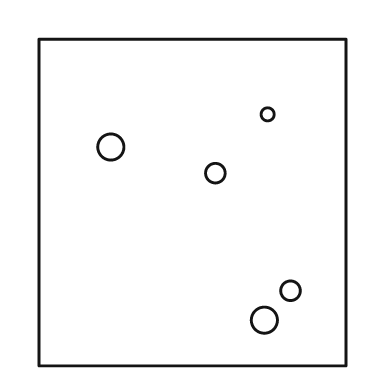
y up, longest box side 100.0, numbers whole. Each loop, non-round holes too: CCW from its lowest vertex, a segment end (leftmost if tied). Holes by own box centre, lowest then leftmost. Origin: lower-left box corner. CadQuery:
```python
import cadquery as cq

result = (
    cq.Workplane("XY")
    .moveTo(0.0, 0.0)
    .lineTo(94.0, 0.0)
    .lineTo(94.0, 100.0)
    .lineTo(0.0, 100.0)
    .close()
    .moveTo(69.0, 14.0)
    .circle(4.0)
    .moveTo(77.0, 23.0)
    .circle(3.0)
    .moveTo(54.0, 59.0)
    .circle(3.0)
    .moveTo(22.0, 67.0)
    .circle(4.0)
    .moveTo(70.0, 77.0)
    .circle(2.0)
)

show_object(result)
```